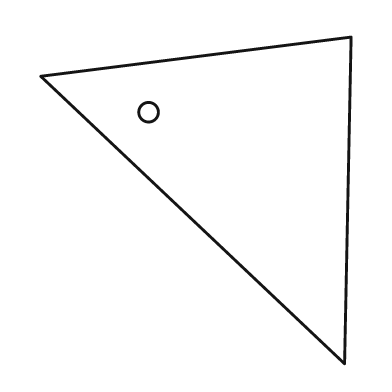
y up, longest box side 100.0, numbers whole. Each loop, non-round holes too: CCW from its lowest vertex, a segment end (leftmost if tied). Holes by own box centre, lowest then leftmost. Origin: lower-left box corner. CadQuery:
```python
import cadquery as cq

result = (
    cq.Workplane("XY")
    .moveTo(93.0, 0.0)
    .lineTo(95.0, 100.0)
    .lineTo(0.0, 88.0)
    .close()
    .moveTo(33.0, 77.0)
    .circle(3.0)
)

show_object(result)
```